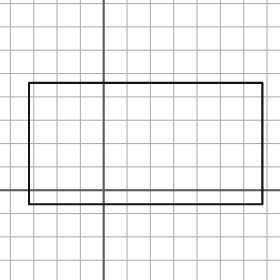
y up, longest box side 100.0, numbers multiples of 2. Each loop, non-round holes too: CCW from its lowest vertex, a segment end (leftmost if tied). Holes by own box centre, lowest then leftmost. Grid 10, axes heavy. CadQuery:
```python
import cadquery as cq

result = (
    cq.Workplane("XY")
    .moveTo(-32.0, -6.0)
    .lineTo(68.0, -6.0)
    .lineTo(68.0, 46.0)
    .lineTo(-32.0, 46.0)
    .close()
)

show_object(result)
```